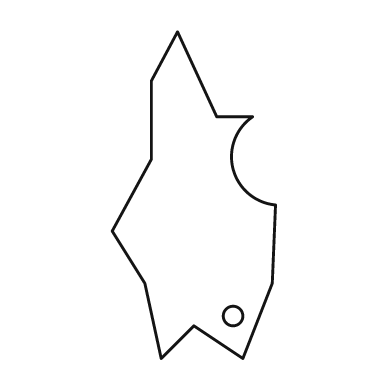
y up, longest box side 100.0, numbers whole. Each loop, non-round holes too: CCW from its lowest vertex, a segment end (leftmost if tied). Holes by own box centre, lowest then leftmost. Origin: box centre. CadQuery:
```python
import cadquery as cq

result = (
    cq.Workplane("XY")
    .moveTo(-10.0, -50.0)
    .lineTo(0.0, -40.0)
    .lineTo(15.0, -50.0)
    .lineTo(24.0, -27.0)
    .lineTo(25.0, -3.0)
    .threePointArc((12.0, 8.0), (18.0, 24.0))
    .lineTo(7.0, 24.0)
    .lineTo(-5.0, 50.0)
    .lineTo(-13.0, 35.0)
    .lineTo(-13.0, 11.0)
    .lineTo(-25.0, -11.0)
    .lineTo(-15.0, -27.0)
    .close()
    .moveTo(12.0, -37.0)
    .circle(3.0)
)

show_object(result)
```